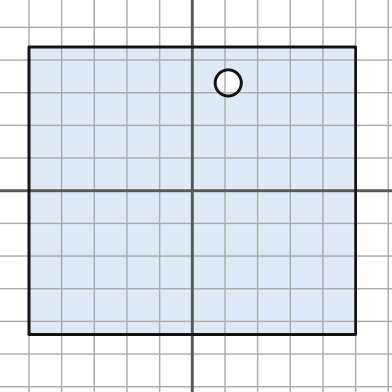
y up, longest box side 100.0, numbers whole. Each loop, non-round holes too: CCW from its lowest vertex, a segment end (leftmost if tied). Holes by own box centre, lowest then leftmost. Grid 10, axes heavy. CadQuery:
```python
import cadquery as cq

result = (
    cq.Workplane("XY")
    .moveTo(-50.0, -44.0)
    .lineTo(50.0, -44.0)
    .lineTo(50.0, 44.0)
    .lineTo(-50.0, 44.0)
    .close()
    .moveTo(11.0, 33.0)
    .circle(4.0)
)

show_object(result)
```